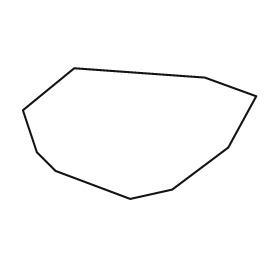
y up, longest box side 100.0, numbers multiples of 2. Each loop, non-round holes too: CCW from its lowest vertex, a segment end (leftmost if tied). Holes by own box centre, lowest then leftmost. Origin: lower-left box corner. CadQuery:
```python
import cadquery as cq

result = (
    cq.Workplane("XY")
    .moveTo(46.0, 0.0)
    .lineTo(64.0, 4.0)
    .lineTo(88.0, 22.0)
    .lineTo(100.0, 44.0)
    .lineTo(78.0, 52.0)
    .lineTo(22.0, 56.0)
    .lineTo(0.0, 38.0)
    .lineTo(6.0, 20.0)
    .lineTo(14.0, 12.0)
    .close()
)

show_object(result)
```